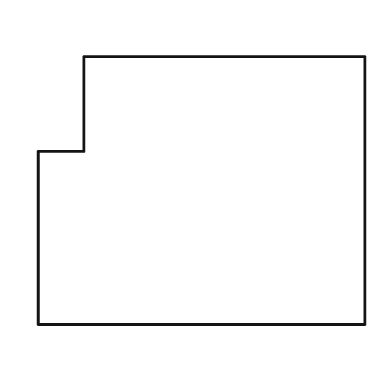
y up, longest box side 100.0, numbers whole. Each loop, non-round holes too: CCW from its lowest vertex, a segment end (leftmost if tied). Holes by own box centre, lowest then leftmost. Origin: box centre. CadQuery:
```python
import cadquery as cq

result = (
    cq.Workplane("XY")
    .moveTo(-50.0, -41.0)
    .lineTo(50.0, -41.0)
    .lineTo(50.0, 41.0)
    .lineTo(-36.0, 41.0)
    .lineTo(-36.0, 12.0)
    .lineTo(-50.0, 12.0)
    .close()
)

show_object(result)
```